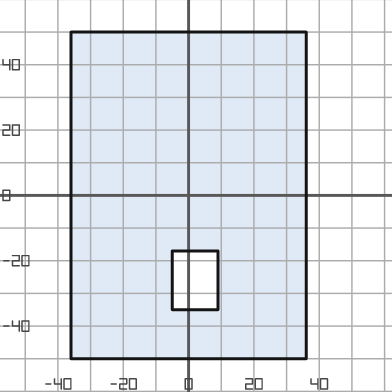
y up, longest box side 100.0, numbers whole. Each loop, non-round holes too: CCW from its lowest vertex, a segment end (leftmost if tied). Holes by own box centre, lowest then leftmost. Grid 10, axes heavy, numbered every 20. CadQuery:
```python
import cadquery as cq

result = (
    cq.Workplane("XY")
    .moveTo(-36.0, -50.0)
    .lineTo(36.0, -50.0)
    .lineTo(36.0, 50.0)
    .lineTo(-36.0, 50.0)
    .close()
    .moveTo(-5.0, -35.0)
    .lineTo(9.0, -35.0)
    .lineTo(9.0, -17.0)
    .lineTo(-5.0, -17.0)
    .close()
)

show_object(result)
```